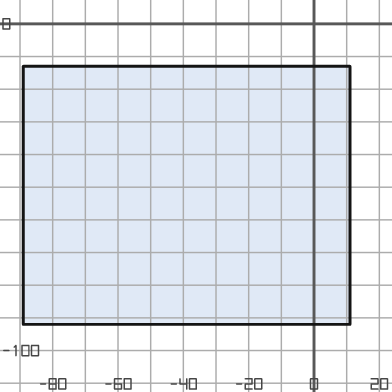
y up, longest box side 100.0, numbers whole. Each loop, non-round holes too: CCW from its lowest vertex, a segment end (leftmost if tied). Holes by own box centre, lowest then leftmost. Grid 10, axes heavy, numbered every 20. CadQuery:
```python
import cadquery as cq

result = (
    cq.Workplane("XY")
    .moveTo(-89.0, -92.0)
    .lineTo(11.0, -92.0)
    .lineTo(11.0, -13.0)
    .lineTo(-89.0, -13.0)
    .close()
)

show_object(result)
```